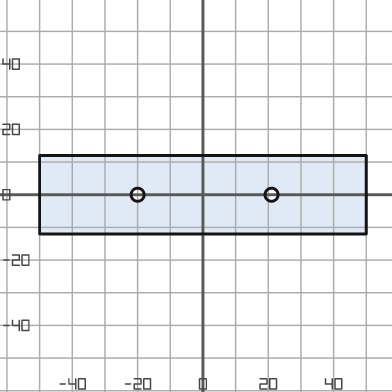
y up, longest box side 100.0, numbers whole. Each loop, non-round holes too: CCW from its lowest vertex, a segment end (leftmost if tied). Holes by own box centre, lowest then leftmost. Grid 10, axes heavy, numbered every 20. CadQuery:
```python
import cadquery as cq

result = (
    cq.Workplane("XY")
    .moveTo(-50.0, -12.0)
    .lineTo(50.0, -12.0)
    .lineTo(50.0, 12.0)
    .lineTo(-50.0, 12.0)
    .close()
    .moveTo(-20.0, 0.0)
    .circle(2.0)
    .moveTo(21.0, 0.0)
    .circle(2.0)
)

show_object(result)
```